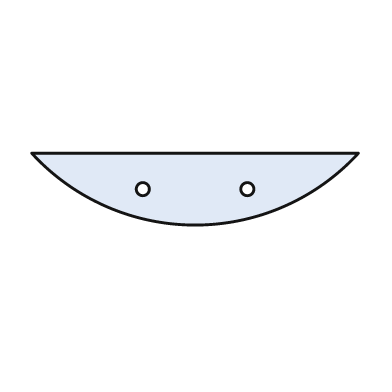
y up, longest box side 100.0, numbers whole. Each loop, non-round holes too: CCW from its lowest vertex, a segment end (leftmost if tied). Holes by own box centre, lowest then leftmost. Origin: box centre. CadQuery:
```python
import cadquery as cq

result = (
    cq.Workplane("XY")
    .moveTo(-50.0, 11.0)
    .threePointArc((0.0, -11.0), (50.0, 11.0))
    .close()
    .moveTo(-16.0, 0.0)
    .circle(2.0)
    .moveTo(16.0, 0.0)
    .circle(2.0)
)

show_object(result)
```